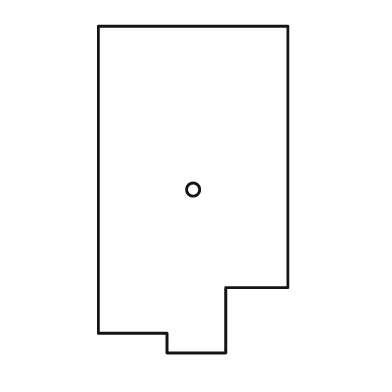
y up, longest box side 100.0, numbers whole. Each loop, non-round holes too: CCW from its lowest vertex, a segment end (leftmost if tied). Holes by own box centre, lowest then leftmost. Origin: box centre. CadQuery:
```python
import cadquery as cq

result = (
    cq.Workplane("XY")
    .moveTo(-8.0, -50.0)
    .lineTo(10.0, -50.0)
    .lineTo(10.0, -30.0)
    .lineTo(29.0, -30.0)
    .lineTo(29.0, 50.0)
    .lineTo(-29.0, 50.0)
    .lineTo(-29.0, -44.0)
    .lineTo(-8.0, -44.0)
    .close()
    .moveTo(0.0, 0.0)
    .circle(2.0)
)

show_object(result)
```